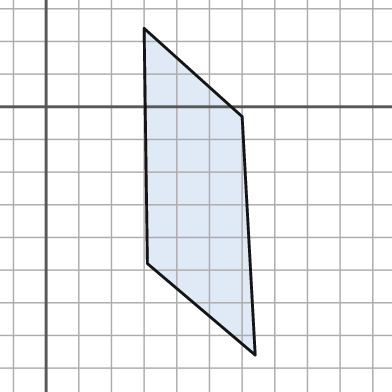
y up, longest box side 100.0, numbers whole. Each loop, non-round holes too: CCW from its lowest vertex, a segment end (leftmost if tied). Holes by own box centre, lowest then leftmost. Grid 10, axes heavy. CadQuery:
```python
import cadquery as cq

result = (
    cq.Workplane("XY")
    .moveTo(64.0, -76.0)
    .lineTo(60.0, -3.0)
    .lineTo(30.0, 24.0)
    .lineTo(31.0, -48.0)
    .close()
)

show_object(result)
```